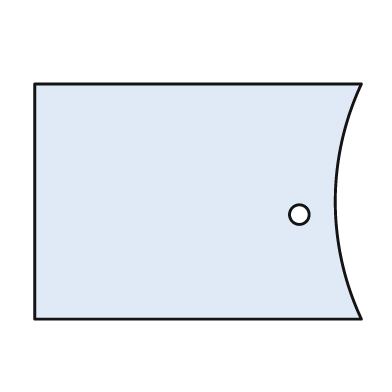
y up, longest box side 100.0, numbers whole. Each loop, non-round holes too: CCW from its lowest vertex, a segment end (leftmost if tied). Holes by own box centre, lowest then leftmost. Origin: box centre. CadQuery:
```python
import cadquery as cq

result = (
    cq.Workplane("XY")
    .moveTo(-50.0, -36.0)
    .lineTo(50.0, -36.0)
    .threePointArc((42.0, 0.0), (50.0, 36.0))
    .lineTo(-50.0, 36.0)
    .close()
    .moveTo(31.0, -4.0)
    .circle(3.0)
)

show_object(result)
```